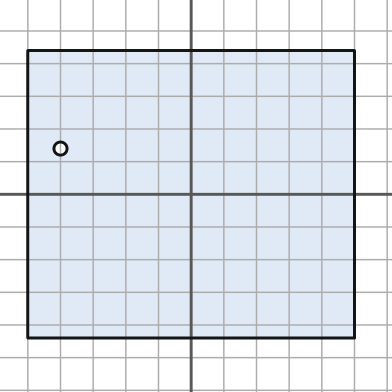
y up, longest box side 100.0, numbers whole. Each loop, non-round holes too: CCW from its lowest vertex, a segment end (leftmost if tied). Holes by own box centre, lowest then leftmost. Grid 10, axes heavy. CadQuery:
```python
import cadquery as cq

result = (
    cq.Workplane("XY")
    .moveTo(-50.0, -44.0)
    .lineTo(50.0, -44.0)
    .lineTo(50.0, 44.0)
    .lineTo(-50.0, 44.0)
    .close()
    .moveTo(-40.0, 14.0)
    .circle(2.0)
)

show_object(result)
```